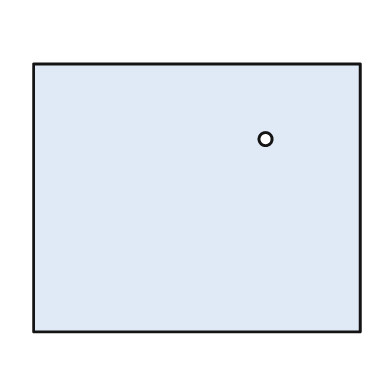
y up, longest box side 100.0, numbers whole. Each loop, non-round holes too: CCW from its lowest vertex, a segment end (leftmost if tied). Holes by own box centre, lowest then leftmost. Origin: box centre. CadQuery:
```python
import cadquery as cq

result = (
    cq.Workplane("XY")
    .moveTo(-50.0, -41.0)
    .lineTo(50.0, -41.0)
    .lineTo(50.0, 41.0)
    .lineTo(-50.0, 41.0)
    .close()
    .moveTo(21.0, 18.0)
    .circle(2.0)
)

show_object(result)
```